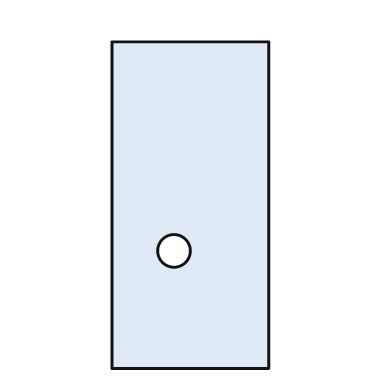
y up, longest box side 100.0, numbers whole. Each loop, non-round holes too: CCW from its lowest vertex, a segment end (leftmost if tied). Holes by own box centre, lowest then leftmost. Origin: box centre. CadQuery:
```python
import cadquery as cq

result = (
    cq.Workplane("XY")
    .moveTo(-24.0, -50.0)
    .lineTo(24.0, -50.0)
    .lineTo(24.0, 50.0)
    .lineTo(-24.0, 50.0)
    .close()
    .moveTo(-5.0, -14.0)
    .circle(5.0)
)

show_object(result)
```